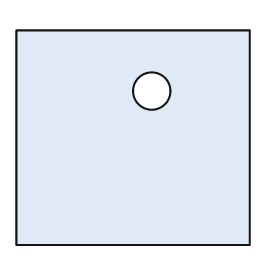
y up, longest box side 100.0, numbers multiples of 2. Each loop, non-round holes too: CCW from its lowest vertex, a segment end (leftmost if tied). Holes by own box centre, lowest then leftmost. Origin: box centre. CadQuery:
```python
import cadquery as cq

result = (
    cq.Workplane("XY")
    .moveTo(-50.0, -46.0)
    .lineTo(50.0, -46.0)
    .lineTo(50.0, 46.0)
    .lineTo(-50.0, 46.0)
    .close()
    .moveTo(8.0, 20.0)
    .circle(8.0)
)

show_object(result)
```